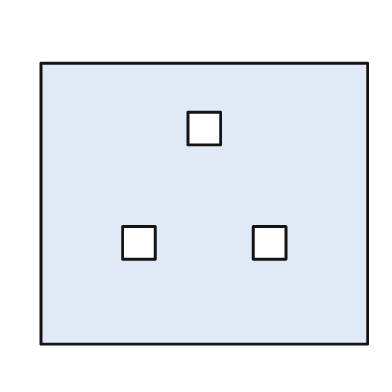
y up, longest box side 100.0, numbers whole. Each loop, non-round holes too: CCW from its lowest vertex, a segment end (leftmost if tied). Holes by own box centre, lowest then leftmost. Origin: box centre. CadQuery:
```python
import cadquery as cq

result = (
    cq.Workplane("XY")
    .moveTo(-50.0, -43.0)
    .lineTo(50.0, -43.0)
    .lineTo(50.0, 43.0)
    .lineTo(-50.0, 43.0)
    .close()
    .moveTo(-25.0, -17.0)
    .lineTo(-15.0, -17.0)
    .lineTo(-15.0, -7.0)
    .lineTo(-25.0, -7.0)
    .close()
    .moveTo(15.0, -17.0)
    .lineTo(25.0, -17.0)
    .lineTo(25.0, -7.0)
    .lineTo(15.0, -7.0)
    .close()
    .moveTo(-5.0, 18.0)
    .lineTo(5.0, 18.0)
    .lineTo(5.0, 28.0)
    .lineTo(-5.0, 28.0)
    .close()
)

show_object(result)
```